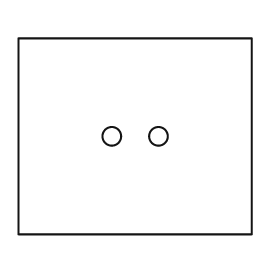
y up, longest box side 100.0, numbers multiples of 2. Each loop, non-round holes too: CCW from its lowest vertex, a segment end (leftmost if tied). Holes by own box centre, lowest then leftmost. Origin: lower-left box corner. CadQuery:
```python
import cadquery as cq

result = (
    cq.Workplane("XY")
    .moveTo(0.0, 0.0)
    .lineTo(100.0, 0.0)
    .lineTo(100.0, 84.0)
    .lineTo(0.0, 84.0)
    .close()
    .moveTo(40.0, 42.0)
    .circle(4.0)
    .moveTo(60.0, 42.0)
    .circle(4.0)
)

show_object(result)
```